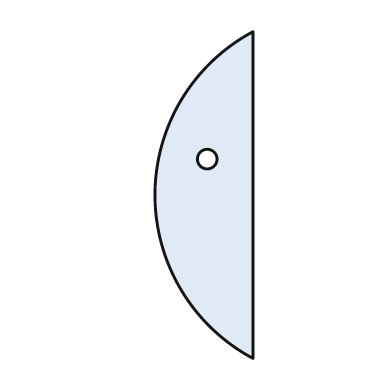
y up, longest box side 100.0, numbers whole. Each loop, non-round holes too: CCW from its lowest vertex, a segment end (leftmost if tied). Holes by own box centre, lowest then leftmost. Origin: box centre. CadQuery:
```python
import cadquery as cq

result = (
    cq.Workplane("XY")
    .moveTo(15.0, -50.0)
    .lineTo(15.0, 50.0)
    .threePointArc((-15.0, 0.0), (15.0, -50.0))
    .close()
    .moveTo(1.0, 11.0)
    .circle(3.0)
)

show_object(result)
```